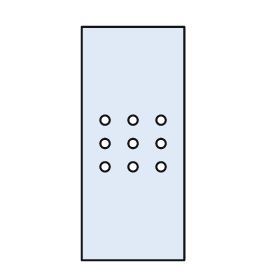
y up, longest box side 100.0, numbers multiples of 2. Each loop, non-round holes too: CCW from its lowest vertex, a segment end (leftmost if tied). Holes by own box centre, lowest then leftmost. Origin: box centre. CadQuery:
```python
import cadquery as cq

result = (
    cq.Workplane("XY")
    .moveTo(-22.0, -50.0)
    .lineTo(22.0, -50.0)
    .lineTo(22.0, 50.0)
    .lineTo(-22.0, 50.0)
    .close()
    .moveTo(-12.0, -10.0)
    .circle(2.0)
    .moveTo(0.0, -10.0)
    .circle(2.0)
    .moveTo(12.0, -10.0)
    .circle(2.0)
    .moveTo(-12.0, 0.0)
    .circle(2.0)
    .moveTo(0.0, 0.0)
    .circle(2.0)
    .moveTo(12.0, 0.0)
    .circle(2.0)
    .moveTo(-12.0, 10.0)
    .circle(2.0)
    .moveTo(0.0, 10.0)
    .circle(2.0)
    .moveTo(12.0, 10.0)
    .circle(2.0)
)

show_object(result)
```